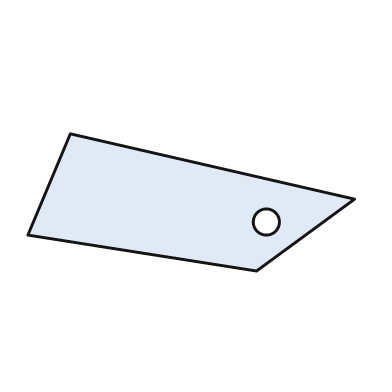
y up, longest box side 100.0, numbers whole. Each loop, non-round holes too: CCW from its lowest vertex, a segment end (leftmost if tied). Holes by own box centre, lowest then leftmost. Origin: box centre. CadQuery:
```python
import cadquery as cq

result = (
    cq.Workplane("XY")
    .moveTo(20.0, -21.0)
    .lineTo(50.0, 1.0)
    .lineTo(-37.0, 21.0)
    .lineTo(-50.0, -10.0)
    .close()
    .moveTo(23.0, -6.0)
    .circle(4.0)
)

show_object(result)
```